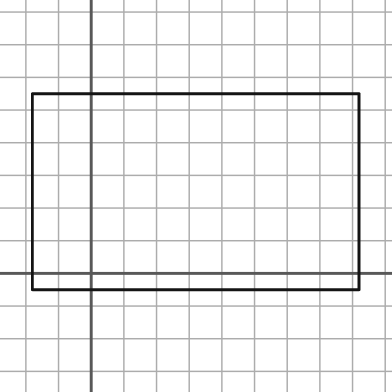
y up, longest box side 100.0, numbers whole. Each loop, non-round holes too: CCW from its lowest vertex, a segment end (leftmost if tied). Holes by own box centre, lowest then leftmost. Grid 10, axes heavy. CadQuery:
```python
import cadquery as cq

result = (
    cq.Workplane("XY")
    .moveTo(-18.0, -5.0)
    .lineTo(82.0, -5.0)
    .lineTo(82.0, 55.0)
    .lineTo(-18.0, 55.0)
    .close()
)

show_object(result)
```